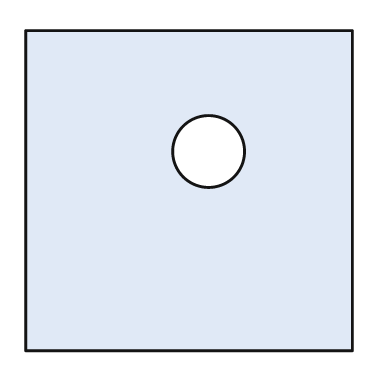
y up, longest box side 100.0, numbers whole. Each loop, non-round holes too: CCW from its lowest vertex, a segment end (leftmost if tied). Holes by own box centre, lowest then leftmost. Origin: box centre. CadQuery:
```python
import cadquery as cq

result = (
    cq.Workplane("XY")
    .moveTo(-50.0, -49.0)
    .lineTo(50.0, -49.0)
    .lineTo(50.0, 49.0)
    .lineTo(-50.0, 49.0)
    .close()
    .moveTo(6.0, 12.0)
    .circle(11.0)
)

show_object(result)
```